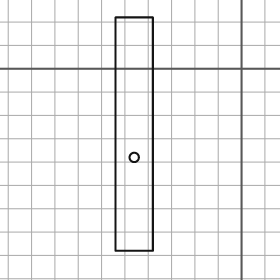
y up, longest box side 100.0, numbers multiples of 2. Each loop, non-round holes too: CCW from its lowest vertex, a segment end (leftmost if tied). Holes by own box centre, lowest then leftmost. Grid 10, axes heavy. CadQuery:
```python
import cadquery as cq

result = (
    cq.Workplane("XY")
    .moveTo(-54.0, -78.0)
    .lineTo(-38.0, -78.0)
    .lineTo(-38.0, 22.0)
    .lineTo(-54.0, 22.0)
    .close()
    .moveTo(-46.0, -38.0)
    .circle(2.0)
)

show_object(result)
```